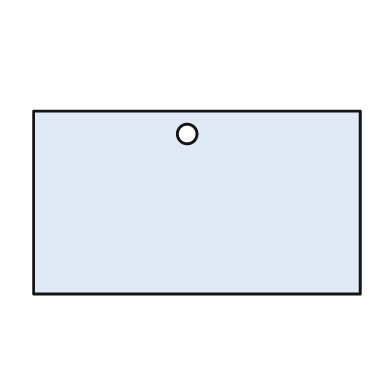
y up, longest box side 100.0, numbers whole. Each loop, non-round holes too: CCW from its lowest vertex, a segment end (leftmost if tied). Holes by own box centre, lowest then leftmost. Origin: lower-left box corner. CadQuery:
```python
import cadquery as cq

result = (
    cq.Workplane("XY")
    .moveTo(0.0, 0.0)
    .lineTo(100.0, 0.0)
    .lineTo(100.0, 56.0)
    .lineTo(0.0, 56.0)
    .close()
    .moveTo(47.0, 49.0)
    .circle(3.0)
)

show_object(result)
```